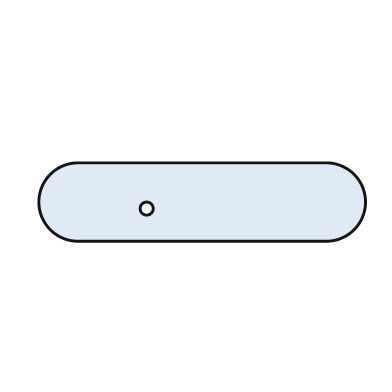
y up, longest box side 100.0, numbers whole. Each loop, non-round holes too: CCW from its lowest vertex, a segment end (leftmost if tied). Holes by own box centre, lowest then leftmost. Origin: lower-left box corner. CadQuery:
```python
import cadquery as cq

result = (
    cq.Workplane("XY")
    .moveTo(12.0, 0.0)
    .lineTo(88.0, 0.0)
    .threePointArc((100.0, 12.0), (88.0, 24.0))
    .lineTo(12.0, 24.0)
    .threePointArc((0.0, 12.0), (12.0, 0.0))
    .close()
    .moveTo(33.0, 10.0)
    .circle(2.0)
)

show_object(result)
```